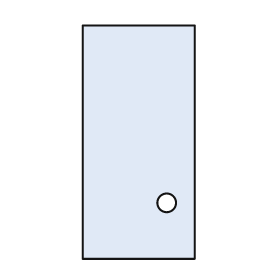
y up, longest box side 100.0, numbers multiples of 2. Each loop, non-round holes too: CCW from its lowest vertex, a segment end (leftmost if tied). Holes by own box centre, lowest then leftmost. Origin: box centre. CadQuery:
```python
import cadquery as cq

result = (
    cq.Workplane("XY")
    .moveTo(-24.0, -50.0)
    .lineTo(24.0, -50.0)
    .lineTo(24.0, 50.0)
    .lineTo(-24.0, 50.0)
    .close()
    .moveTo(12.0, -26.0)
    .circle(4.0)
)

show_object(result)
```